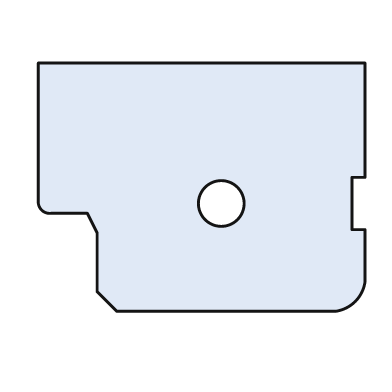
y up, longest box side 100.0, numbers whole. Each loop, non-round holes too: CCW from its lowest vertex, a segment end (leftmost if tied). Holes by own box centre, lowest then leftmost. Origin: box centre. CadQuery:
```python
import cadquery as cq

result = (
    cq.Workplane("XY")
    .moveTo(-26.0, -38.0)
    .lineTo(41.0, -38.0)
    .threePointArc((47.0, -35.0), (50.0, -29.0))
    .lineTo(50.0, -13.0)
    .lineTo(46.0, -13.0)
    .lineTo(46.0, 3.0)
    .lineTo(50.0, 3.0)
    .lineTo(50.0, 38.0)
    .lineTo(-50.0, 38.0)
    .lineTo(-50.0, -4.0)
    .threePointArc((-49.0, -7.0), (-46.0, -8.0))
    .lineTo(-35.0, -8.0)
    .lineTo(-32.0, -14.0)
    .lineTo(-32.0, -32.0)
    .close()
    .moveTo(6.0, -5.0)
    .circle(7.0)
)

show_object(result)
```